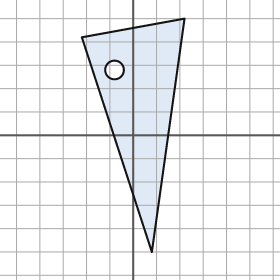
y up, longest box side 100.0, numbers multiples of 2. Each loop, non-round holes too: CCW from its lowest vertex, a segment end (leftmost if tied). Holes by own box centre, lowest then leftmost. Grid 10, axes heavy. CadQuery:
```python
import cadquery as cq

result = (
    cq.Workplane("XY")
    .moveTo(8.0, -50.0)
    .lineTo(22.0, 50.0)
    .lineTo(-22.0, 42.0)
    .close()
    .moveTo(-8.0, 28.0)
    .circle(4.0)
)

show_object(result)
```